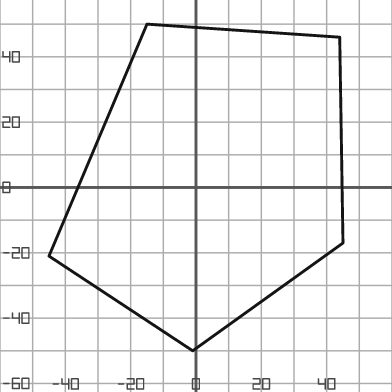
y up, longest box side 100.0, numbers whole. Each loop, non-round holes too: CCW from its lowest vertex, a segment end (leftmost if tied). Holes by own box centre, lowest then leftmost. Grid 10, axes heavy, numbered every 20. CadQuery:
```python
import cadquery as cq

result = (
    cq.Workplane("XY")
    .moveTo(-1.0, -50.0)
    .lineTo(45.0, -17.0)
    .lineTo(44.0, 46.0)
    .lineTo(-15.0, 50.0)
    .lineTo(-45.0, -21.0)
    .close()
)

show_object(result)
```